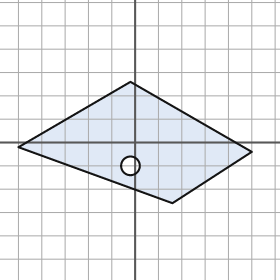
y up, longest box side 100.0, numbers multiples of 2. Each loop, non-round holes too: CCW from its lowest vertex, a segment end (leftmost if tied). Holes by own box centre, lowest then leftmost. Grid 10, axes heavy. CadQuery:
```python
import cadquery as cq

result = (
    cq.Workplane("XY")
    .moveTo(16.0, -26.0)
    .lineTo(50.0, -4.0)
    .lineTo(-2.0, 26.0)
    .lineTo(-50.0, -2.0)
    .close()
    .moveTo(-2.0, -10.0)
    .circle(4.0)
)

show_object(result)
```